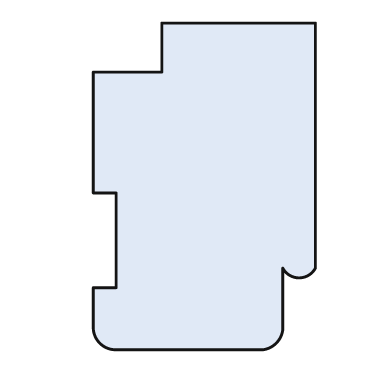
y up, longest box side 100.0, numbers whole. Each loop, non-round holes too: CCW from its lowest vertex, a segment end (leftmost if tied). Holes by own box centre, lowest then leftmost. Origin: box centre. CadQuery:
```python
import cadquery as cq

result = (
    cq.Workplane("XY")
    .moveTo(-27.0, -50.0)
    .lineTo(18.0, -50.0)
    .threePointArc((22.0, -48.0), (24.0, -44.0))
    .lineTo(24.0, -25.0)
    .threePointArc((29.0, -28.0), (34.0, -25.0))
    .lineTo(34.0, 50.0)
    .lineTo(-13.0, 50.0)
    .lineTo(-13.0, 35.0)
    .lineTo(-34.0, 35.0)
    .lineTo(-34.0, -2.0)
    .lineTo(-27.0, -2.0)
    .lineTo(-27.0, -31.0)
    .lineTo(-34.0, -31.0)
    .lineTo(-34.0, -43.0)
    .threePointArc((-32.0, -48.0), (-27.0, -50.0))
    .close()
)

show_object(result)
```